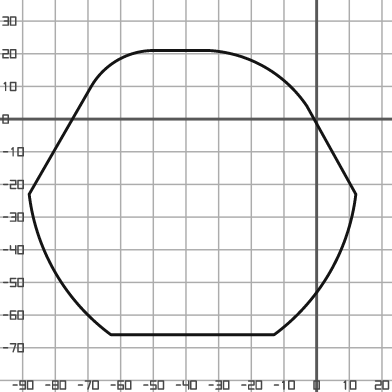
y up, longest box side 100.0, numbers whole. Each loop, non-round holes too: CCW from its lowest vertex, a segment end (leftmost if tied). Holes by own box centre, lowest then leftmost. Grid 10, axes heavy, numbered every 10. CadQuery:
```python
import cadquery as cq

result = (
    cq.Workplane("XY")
    .moveTo(-63.0, -66.0)
    .lineTo(-13.0, -66.0)
    .threePointArc((4.0, -47.0), (12.0, -23.0))
    .lineTo(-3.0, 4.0)
    .threePointArc((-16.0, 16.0), (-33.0, 21.0))
    .lineTo(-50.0, 21.0)
    .threePointArc((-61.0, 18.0), (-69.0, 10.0))
    .lineTo(-88.0, -23.0)
    .threePointArc((-80.0, -47.0), (-63.0, -66.0))
    .close()
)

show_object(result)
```